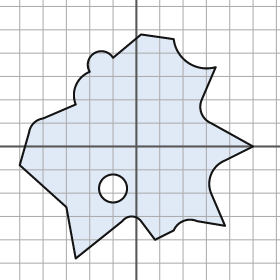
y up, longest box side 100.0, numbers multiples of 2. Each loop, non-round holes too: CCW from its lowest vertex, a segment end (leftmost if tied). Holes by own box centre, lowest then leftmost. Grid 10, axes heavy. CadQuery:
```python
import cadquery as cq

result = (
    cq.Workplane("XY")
    .moveTo(-26.0, -48.0)
    .lineTo(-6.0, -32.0)
    .threePointArc((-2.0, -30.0), (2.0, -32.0))
    .lineTo(8.0, -40.0)
    .lineTo(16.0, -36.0)
    .threePointArc((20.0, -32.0), (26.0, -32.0))
    .lineTo(38.0, -34.0)
    .lineTo(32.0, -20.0)
    .threePointArc((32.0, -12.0), (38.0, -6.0))
    .lineTo(50.0, 0.0)
    .lineTo(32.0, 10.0)
    .threePointArc((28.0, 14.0), (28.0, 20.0))
    .lineTo(34.0, 34.0)
    .threePointArc((22.0, 36.0), (16.0, 46.0))
    .lineTo(2.0, 48.0)
    .lineTo(-10.0, 38.0)
    .threePointArc((-18.0, 40.0), (-20.0, 32.0))
    .threePointArc((-26.0, 26.0), (-26.0, 18.0))
    .lineTo(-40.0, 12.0)
    .threePointArc((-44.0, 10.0), (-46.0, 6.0))
    .lineTo(-50.0, -8.0)
    .lineTo(-30.0, -26.0)
    .close()
    .moveTo(-10.0, -18.0)
    .circle(6.0)
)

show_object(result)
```